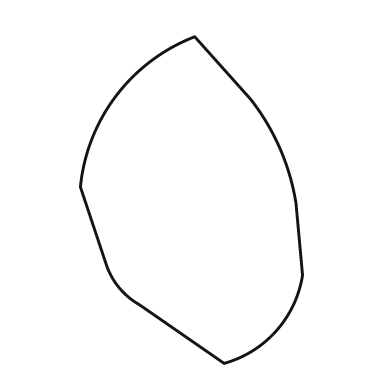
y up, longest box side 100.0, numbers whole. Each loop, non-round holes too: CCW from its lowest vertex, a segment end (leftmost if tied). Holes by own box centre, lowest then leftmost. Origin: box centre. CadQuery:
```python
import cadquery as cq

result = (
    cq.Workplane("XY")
    .moveTo(10.0, -50.0)
    .threePointArc((26.0, -40.0), (34.0, -23.0))
    .lineTo(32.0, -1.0)
    .threePointArc((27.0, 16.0), (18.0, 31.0))
    .lineTo(1.0, 50.0)
    .threePointArc((-23.0, 32.0), (-34.0, 4.0))
    .lineTo(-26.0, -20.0)
    .threePointArc((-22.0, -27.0), (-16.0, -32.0))
    .close()
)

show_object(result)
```